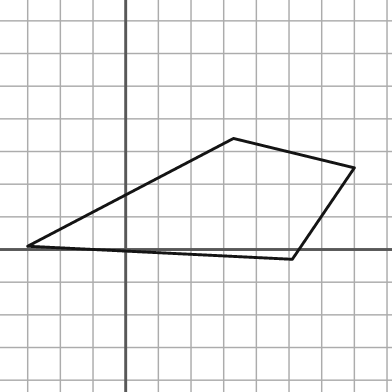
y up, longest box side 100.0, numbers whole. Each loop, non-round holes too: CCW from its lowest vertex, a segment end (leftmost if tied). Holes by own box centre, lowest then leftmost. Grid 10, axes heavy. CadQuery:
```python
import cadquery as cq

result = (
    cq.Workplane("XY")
    .moveTo(51.0, -3.0)
    .lineTo(70.0, 25.0)
    .lineTo(33.0, 34.0)
    .lineTo(-30.0, 1.0)
    .close()
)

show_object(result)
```